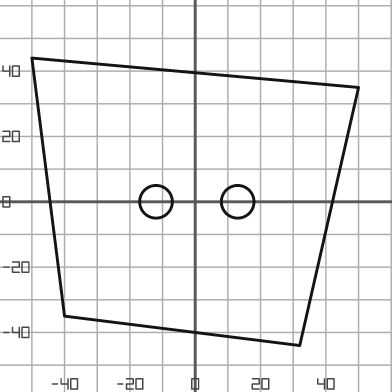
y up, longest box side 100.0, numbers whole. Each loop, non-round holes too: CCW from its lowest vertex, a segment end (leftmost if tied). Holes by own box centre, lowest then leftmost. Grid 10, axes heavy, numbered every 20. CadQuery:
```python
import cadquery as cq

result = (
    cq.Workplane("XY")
    .moveTo(32.0, -44.0)
    .lineTo(50.0, 35.0)
    .lineTo(-50.0, 44.0)
    .lineTo(-40.0, -35.0)
    .close()
    .moveTo(-12.0, 0.0)
    .circle(5.0)
    .moveTo(13.0, 0.0)
    .circle(5.0)
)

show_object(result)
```